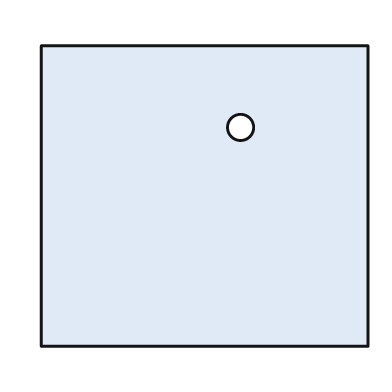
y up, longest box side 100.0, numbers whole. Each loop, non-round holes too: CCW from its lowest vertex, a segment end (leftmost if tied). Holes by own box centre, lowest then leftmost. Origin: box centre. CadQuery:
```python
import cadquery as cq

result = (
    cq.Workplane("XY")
    .moveTo(-50.0, -46.0)
    .lineTo(50.0, -46.0)
    .lineTo(50.0, 46.0)
    .lineTo(-50.0, 46.0)
    .close()
    .moveTo(11.0, 21.0)
    .circle(4.0)
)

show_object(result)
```